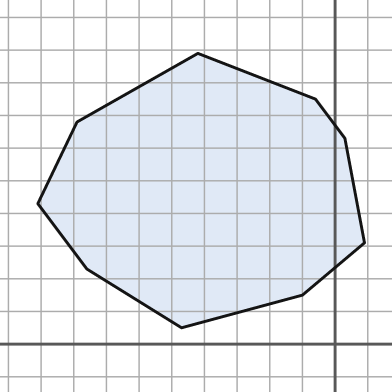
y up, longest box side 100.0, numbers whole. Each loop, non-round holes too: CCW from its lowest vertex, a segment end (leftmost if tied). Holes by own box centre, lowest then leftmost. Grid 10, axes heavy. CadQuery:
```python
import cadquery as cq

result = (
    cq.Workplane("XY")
    .moveTo(-47.0, 5.0)
    .lineTo(-10.0, 15.0)
    .lineTo(9.0, 31.0)
    .lineTo(3.0, 63.0)
    .lineTo(-6.0, 75.0)
    .lineTo(-42.0, 89.0)
    .lineTo(-79.0, 68.0)
    .lineTo(-91.0, 43.0)
    .lineTo(-76.0, 23.0)
    .close()
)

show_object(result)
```